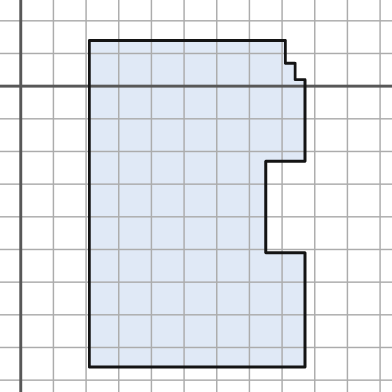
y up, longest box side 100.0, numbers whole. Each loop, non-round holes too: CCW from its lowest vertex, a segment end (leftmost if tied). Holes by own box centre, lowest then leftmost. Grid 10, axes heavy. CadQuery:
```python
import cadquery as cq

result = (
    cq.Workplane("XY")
    .moveTo(21.0, -86.0)
    .lineTo(87.0, -86.0)
    .lineTo(87.0, -51.0)
    .lineTo(75.0, -51.0)
    .lineTo(75.0, -23.0)
    .lineTo(87.0, -23.0)
    .lineTo(87.0, 2.0)
    .lineTo(84.0, 2.0)
    .lineTo(84.0, 7.0)
    .lineTo(81.0, 7.0)
    .lineTo(81.0, 14.0)
    .lineTo(21.0, 14.0)
    .close()
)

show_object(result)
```